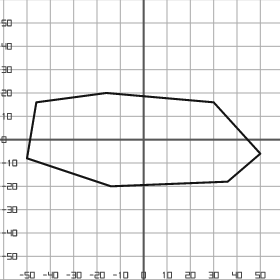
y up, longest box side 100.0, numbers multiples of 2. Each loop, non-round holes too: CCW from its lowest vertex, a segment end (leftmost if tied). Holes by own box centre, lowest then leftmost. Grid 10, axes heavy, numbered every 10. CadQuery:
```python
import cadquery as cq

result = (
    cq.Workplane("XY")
    .moveTo(-14.0, -20.0)
    .lineTo(36.0, -18.0)
    .lineTo(50.0, -6.0)
    .lineTo(30.0, 16.0)
    .lineTo(-16.0, 20.0)
    .lineTo(-46.0, 16.0)
    .lineTo(-50.0, -8.0)
    .close()
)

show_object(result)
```